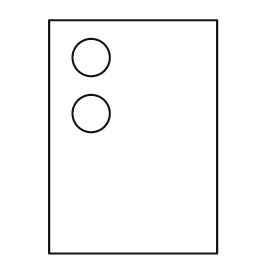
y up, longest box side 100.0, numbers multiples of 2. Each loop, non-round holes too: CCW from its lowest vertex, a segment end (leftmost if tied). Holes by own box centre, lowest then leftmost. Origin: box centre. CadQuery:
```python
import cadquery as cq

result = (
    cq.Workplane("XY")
    .moveTo(-36.0, -50.0)
    .lineTo(36.0, -50.0)
    .lineTo(36.0, 50.0)
    .lineTo(-36.0, 50.0)
    .close()
    .moveTo(-18.0, 10.0)
    .circle(8.0)
    .moveTo(-18.0, 34.0)
    .circle(8.0)
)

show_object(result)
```